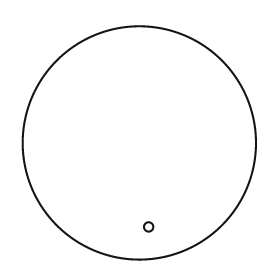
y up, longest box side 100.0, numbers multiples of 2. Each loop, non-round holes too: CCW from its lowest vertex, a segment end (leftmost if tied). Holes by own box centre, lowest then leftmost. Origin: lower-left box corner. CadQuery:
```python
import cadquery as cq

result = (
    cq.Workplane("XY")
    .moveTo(50.0, 50.0)
    .circle(50.0)
    .moveTo(54.0, 14.0)
    .circle(2.0)
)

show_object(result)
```